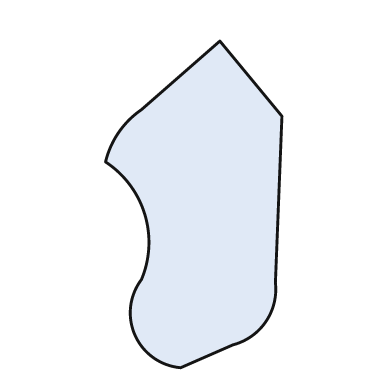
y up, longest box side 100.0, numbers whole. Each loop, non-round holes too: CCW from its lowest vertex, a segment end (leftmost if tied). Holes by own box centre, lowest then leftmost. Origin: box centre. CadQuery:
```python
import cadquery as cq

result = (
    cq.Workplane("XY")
    .moveTo(-4.0, -50.0)
    .lineTo(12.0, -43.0)
    .threePointArc((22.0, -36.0), (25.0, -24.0))
    .lineTo(27.0, 27.0)
    .lineTo(8.0, 50.0)
    .lineTo(-16.0, 29.0)
    .threePointArc((-23.0, 22.0), (-27.0, 13.0))
    .threePointArc((-15.0, -3.0), (-16.0, -23.0))
    .threePointArc((-18.0, -40.0), (-4.0, -50.0))
    .close()
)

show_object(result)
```